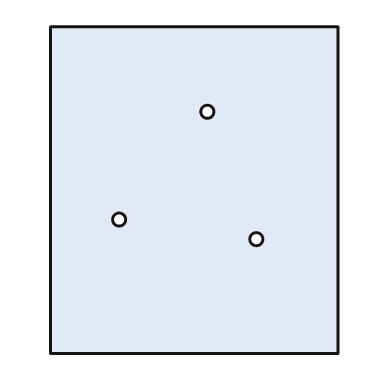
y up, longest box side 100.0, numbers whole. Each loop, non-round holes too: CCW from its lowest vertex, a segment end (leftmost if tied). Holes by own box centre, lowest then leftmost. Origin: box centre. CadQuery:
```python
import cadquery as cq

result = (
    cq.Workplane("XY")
    .moveTo(-44.0, -50.0)
    .lineTo(44.0, -50.0)
    .lineTo(44.0, 50.0)
    .lineTo(-44.0, 50.0)
    .close()
    .moveTo(19.0, -15.0)
    .circle(2.0)
    .moveTo(-23.0, -9.0)
    .circle(2.0)
    .moveTo(4.0, 24.0)
    .circle(2.0)
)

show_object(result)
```